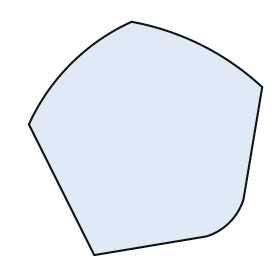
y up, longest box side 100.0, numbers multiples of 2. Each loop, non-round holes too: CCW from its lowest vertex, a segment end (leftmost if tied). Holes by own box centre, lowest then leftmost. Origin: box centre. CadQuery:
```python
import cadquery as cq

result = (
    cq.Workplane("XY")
    .moveTo(-22.0, -50.0)
    .lineTo(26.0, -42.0)
    .threePointArc((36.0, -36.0), (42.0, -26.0))
    .lineTo(50.0, 22.0)
    .threePointArc((24.0, 40.0), (-6.0, 50.0))
    .threePointArc((-32.0, 32.0), (-50.0, 6.0))
    .close()
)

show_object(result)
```